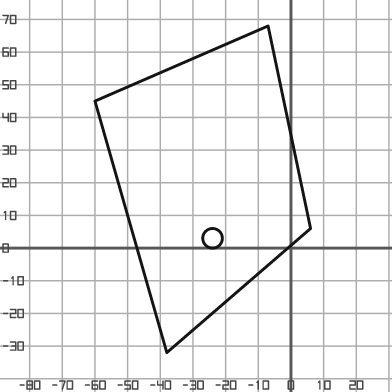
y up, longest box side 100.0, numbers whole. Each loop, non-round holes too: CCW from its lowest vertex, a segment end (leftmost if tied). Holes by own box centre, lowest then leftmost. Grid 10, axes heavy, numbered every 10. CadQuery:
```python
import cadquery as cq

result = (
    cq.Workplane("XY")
    .moveTo(-38.0, -32.0)
    .lineTo(6.0, 6.0)
    .lineTo(-7.0, 68.0)
    .lineTo(-60.0, 45.0)
    .close()
    .moveTo(-24.0, 3.0)
    .circle(3.0)
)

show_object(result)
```